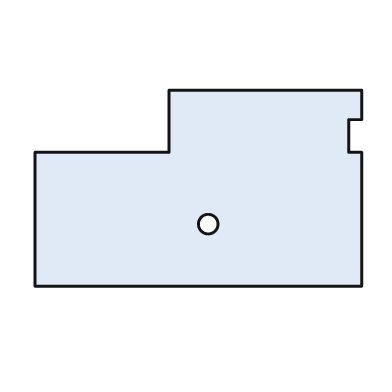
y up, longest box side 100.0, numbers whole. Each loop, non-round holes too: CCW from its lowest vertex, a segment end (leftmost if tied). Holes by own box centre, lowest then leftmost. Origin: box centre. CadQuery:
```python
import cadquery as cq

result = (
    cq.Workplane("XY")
    .moveTo(-50.0, -30.0)
    .lineTo(50.0, -30.0)
    .lineTo(50.0, 11.0)
    .lineTo(46.0, 11.0)
    .lineTo(46.0, 21.0)
    .lineTo(50.0, 21.0)
    .lineTo(50.0, 30.0)
    .lineTo(-9.0, 30.0)
    .lineTo(-9.0, 11.0)
    .lineTo(-50.0, 11.0)
    .close()
    .moveTo(3.0, -11.0)
    .circle(3.0)
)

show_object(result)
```